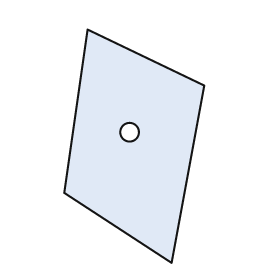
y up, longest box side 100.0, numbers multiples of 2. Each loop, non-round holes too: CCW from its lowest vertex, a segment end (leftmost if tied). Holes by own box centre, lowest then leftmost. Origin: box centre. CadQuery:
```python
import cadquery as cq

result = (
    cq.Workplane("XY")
    .moveTo(16.0, -50.0)
    .lineTo(30.0, 26.0)
    .lineTo(-20.0, 50.0)
    .lineTo(-30.0, -20.0)
    .close()
    .moveTo(-2.0, 6.0)
    .circle(4.0)
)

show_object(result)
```